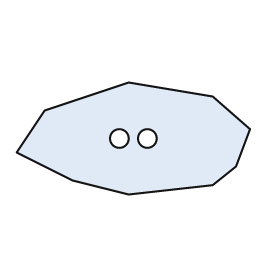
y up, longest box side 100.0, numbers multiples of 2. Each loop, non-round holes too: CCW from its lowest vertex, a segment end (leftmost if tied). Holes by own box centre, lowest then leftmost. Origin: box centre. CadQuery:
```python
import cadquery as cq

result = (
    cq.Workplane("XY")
    .moveTo(-2.0, -24.0)
    .lineTo(34.0, -20.0)
    .lineTo(44.0, -12.0)
    .lineTo(50.0, 4.0)
    .lineTo(34.0, 18.0)
    .lineTo(-2.0, 24.0)
    .lineTo(-38.0, 12.0)
    .lineTo(-50.0, -6.0)
    .lineTo(-26.0, -18.0)
    .close()
    .moveTo(-6.0, 0.0)
    .circle(4.0)
    .moveTo(6.0, 0.0)
    .circle(4.0)
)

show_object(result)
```